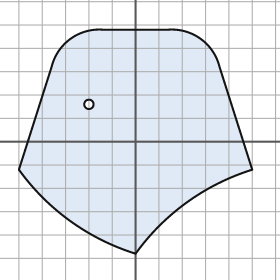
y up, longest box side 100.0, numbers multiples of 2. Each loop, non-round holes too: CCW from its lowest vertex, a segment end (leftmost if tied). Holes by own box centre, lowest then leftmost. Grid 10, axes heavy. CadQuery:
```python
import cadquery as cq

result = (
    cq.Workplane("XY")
    .moveTo(0.0, -48.0)
    .threePointArc((22.0, -26.0), (50.0, -12.0))
    .lineTo(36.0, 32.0)
    .threePointArc((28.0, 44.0), (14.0, 48.0))
    .lineTo(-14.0, 48.0)
    .threePointArc((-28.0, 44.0), (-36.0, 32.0))
    .lineTo(-50.0, -12.0)
    .threePointArc((-28.0, -34.0), (0.0, -48.0))
    .close()
    .moveTo(-20.0, 16.0)
    .circle(2.0)
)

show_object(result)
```